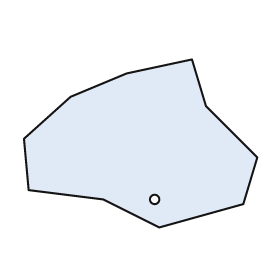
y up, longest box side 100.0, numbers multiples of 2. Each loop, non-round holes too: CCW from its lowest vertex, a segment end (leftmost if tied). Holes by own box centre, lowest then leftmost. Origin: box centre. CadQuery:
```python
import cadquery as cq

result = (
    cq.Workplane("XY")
    .moveTo(8.0, -36.0)
    .lineTo(44.0, -26.0)
    .lineTo(50.0, -6.0)
    .lineTo(28.0, 16.0)
    .lineTo(22.0, 36.0)
    .lineTo(-6.0, 30.0)
    .lineTo(-30.0, 20.0)
    .lineTo(-50.0, 2.0)
    .lineTo(-48.0, -20.0)
    .lineTo(-16.0, -24.0)
    .close()
    .moveTo(6.0, -24.0)
    .circle(2.0)
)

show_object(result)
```